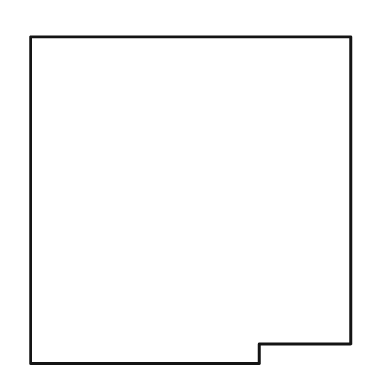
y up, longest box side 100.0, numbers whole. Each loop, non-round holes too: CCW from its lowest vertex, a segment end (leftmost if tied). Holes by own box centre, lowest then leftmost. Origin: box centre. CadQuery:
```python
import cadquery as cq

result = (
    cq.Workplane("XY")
    .moveTo(-49.0, -50.0)
    .lineTo(21.0, -50.0)
    .lineTo(21.0, -44.0)
    .lineTo(49.0, -44.0)
    .lineTo(49.0, 50.0)
    .lineTo(-49.0, 50.0)
    .close()
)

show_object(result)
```